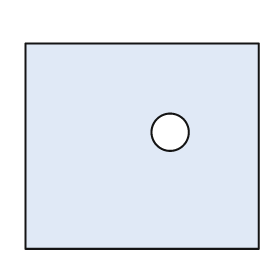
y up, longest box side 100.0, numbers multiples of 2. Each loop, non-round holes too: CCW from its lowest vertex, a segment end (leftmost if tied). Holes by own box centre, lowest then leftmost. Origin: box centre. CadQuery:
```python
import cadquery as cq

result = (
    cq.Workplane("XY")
    .moveTo(-50.0, -44.0)
    .lineTo(50.0, -44.0)
    .lineTo(50.0, 44.0)
    .lineTo(-50.0, 44.0)
    .close()
    .moveTo(12.0, 6.0)
    .circle(8.0)
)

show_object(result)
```